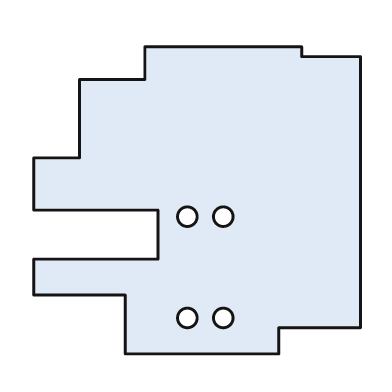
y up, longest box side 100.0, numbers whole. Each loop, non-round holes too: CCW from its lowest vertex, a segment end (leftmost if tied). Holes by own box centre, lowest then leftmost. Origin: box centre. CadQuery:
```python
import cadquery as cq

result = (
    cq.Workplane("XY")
    .moveTo(-22.0, -47.0)
    .lineTo(25.0, -47.0)
    .lineTo(25.0, -39.0)
    .lineTo(50.0, -39.0)
    .lineTo(50.0, 44.0)
    .lineTo(32.0, 44.0)
    .lineTo(32.0, 47.0)
    .lineTo(-16.0, 47.0)
    .lineTo(-16.0, 37.0)
    .lineTo(-36.0, 37.0)
    .lineTo(-36.0, 13.0)
    .lineTo(-50.0, 13.0)
    .lineTo(-50.0, -3.0)
    .lineTo(-12.0, -3.0)
    .lineTo(-12.0, -18.0)
    .lineTo(-50.0, -18.0)
    .lineTo(-50.0, -29.0)
    .lineTo(-22.0, -29.0)
    .close()
    .moveTo(-3.0, -36.0)
    .circle(3.0)
    .moveTo(8.0, -36.0)
    .circle(3.0)
    .moveTo(-3.0, -5.0)
    .circle(3.0)
    .moveTo(8.0, -5.0)
    .circle(3.0)
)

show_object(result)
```